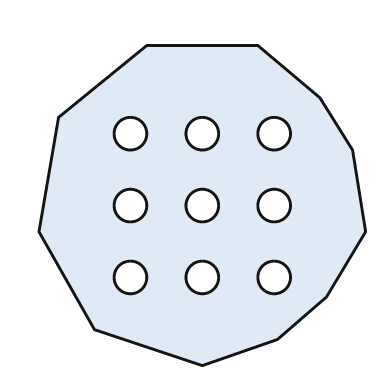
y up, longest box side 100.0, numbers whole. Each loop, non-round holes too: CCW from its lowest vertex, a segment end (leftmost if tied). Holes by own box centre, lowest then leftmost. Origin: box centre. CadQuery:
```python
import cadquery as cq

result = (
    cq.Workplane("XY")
    .moveTo(0.0, -49.0)
    .lineTo(23.0, -41.0)
    .lineTo(38.0, -28.0)
    .lineTo(50.0, -8.0)
    .lineTo(46.0, 17.0)
    .lineTo(36.0, 33.0)
    .lineTo(17.0, 49.0)
    .lineTo(-17.0, 49.0)
    .lineTo(-44.0, 27.0)
    .lineTo(-50.0, -8.0)
    .lineTo(-33.0, -38.0)
    .close()
    .moveTo(-22.0, -22.0)
    .circle(5.0)
    .moveTo(0.0, -22.0)
    .circle(5.0)
    .moveTo(22.0, -22.0)
    .circle(5.0)
    .moveTo(-22.0, 0.0)
    .circle(5.0)
    .moveTo(0.0, 0.0)
    .circle(5.0)
    .moveTo(22.0, 0.0)
    .circle(5.0)
    .moveTo(-22.0, 22.0)
    .circle(5.0)
    .moveTo(0.0, 22.0)
    .circle(5.0)
    .moveTo(22.0, 22.0)
    .circle(5.0)
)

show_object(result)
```